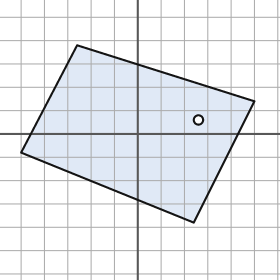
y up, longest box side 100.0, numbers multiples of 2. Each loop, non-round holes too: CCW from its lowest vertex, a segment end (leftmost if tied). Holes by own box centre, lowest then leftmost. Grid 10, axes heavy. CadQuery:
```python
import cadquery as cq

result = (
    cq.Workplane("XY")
    .moveTo(24.0, -38.0)
    .lineTo(50.0, 14.0)
    .lineTo(-26.0, 38.0)
    .lineTo(-50.0, -8.0)
    .close()
    .moveTo(26.0, 6.0)
    .circle(2.0)
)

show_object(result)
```